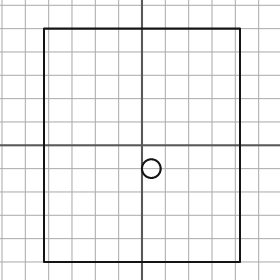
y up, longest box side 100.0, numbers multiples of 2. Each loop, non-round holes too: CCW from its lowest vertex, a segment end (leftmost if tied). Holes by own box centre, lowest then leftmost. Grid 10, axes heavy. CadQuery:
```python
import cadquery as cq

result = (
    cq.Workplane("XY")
    .moveTo(-42.0, -50.0)
    .lineTo(42.0, -50.0)
    .lineTo(42.0, 50.0)
    .lineTo(-42.0, 50.0)
    .close()
    .moveTo(4.0, -10.0)
    .circle(4.0)
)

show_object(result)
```